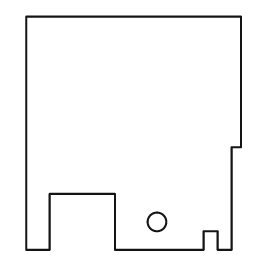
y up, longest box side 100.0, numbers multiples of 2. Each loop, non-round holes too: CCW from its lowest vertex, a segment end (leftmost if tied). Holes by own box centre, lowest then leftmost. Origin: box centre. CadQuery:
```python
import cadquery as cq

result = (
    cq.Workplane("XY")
    .moveTo(-46.0, -50.0)
    .lineTo(-36.0, -50.0)
    .lineTo(-36.0, -26.0)
    .lineTo(-8.0, -26.0)
    .lineTo(-8.0, -50.0)
    .lineTo(30.0, -50.0)
    .lineTo(30.0, -42.0)
    .lineTo(36.0, -42.0)
    .lineTo(36.0, -50.0)
    .lineTo(42.0, -50.0)
    .lineTo(42.0, -6.0)
    .lineTo(46.0, -6.0)
    .lineTo(46.0, 50.0)
    .lineTo(-46.0, 50.0)
    .close()
    .moveTo(10.0, -38.0)
    .circle(4.0)
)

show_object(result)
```